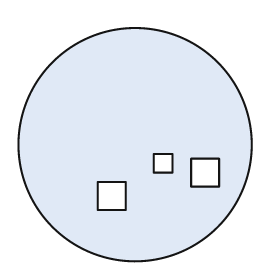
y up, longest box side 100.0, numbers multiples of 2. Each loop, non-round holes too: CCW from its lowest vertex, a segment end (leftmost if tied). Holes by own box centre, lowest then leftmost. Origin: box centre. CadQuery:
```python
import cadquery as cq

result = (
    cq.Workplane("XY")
    .moveTo(0.0, 0.0)
    .circle(50.0)
    .moveTo(-16.0, -28.0)
    .lineTo(-4.0, -28.0)
    .lineTo(-4.0, -16.0)
    .lineTo(-16.0, -16.0)
    .close()
    .moveTo(24.0, -18.0)
    .lineTo(36.0, -18.0)
    .lineTo(36.0, -6.0)
    .lineTo(24.0, -6.0)
    .close()
    .moveTo(8.0, -12.0)
    .lineTo(16.0, -12.0)
    .lineTo(16.0, -4.0)
    .lineTo(8.0, -4.0)
    .close()
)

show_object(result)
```